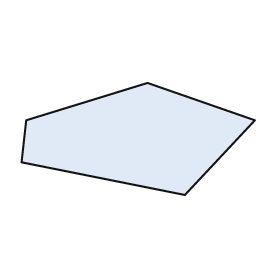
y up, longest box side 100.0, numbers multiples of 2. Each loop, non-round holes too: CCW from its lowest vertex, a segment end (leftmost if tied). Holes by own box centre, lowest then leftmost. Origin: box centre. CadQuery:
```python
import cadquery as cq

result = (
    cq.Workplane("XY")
    .moveTo(20.0, -24.0)
    .lineTo(50.0, 8.0)
    .lineTo(4.0, 24.0)
    .lineTo(-48.0, 8.0)
    .lineTo(-50.0, -10.0)
    .close()
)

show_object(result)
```